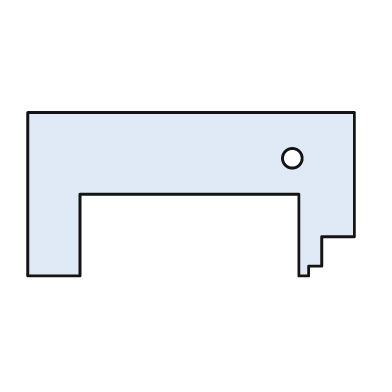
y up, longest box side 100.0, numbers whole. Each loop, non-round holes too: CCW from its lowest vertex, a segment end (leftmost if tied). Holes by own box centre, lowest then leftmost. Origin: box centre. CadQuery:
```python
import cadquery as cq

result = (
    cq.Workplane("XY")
    .moveTo(-50.0, -25.0)
    .lineTo(-34.0, -25.0)
    .lineTo(-34.0, 0.0)
    .lineTo(33.0, 0.0)
    .lineTo(33.0, -25.0)
    .lineTo(36.0, -25.0)
    .lineTo(36.0, -22.0)
    .lineTo(40.0, -22.0)
    .lineTo(40.0, -13.0)
    .lineTo(50.0, -13.0)
    .lineTo(50.0, 25.0)
    .lineTo(-50.0, 25.0)
    .close()
    .moveTo(31.0, 11.0)
    .circle(3.0)
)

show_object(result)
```